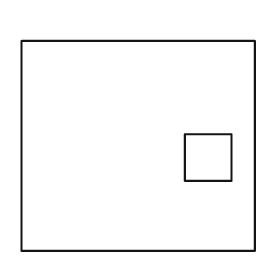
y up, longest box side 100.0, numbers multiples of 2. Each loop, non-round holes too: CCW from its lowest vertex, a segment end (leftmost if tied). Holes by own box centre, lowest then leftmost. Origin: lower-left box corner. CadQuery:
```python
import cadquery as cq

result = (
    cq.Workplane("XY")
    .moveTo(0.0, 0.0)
    .lineTo(100.0, 0.0)
    .lineTo(100.0, 90.0)
    .lineTo(0.0, 90.0)
    .close()
    .moveTo(70.0, 30.0)
    .lineTo(90.0, 30.0)
    .lineTo(90.0, 50.0)
    .lineTo(70.0, 50.0)
    .close()
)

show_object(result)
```